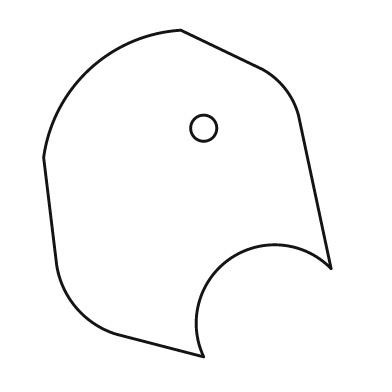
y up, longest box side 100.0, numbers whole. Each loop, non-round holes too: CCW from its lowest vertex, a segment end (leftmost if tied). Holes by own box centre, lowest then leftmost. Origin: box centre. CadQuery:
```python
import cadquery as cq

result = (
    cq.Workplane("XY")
    .moveTo(5.0, -50.0)
    .threePointArc((13.0, -20.0), (44.0, -23.0))
    .lineTo(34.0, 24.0)
    .threePointArc((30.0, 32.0), (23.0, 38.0))
    .lineTo(-2.0, 50.0)
    .threePointArc((-30.0, 38.0), (-44.0, 11.0))
    .lineTo(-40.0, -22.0)
    .threePointArc((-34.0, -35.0), (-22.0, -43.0))
    .close()
    .moveTo(5.0, 20.0)
    .circle(4.0)
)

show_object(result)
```